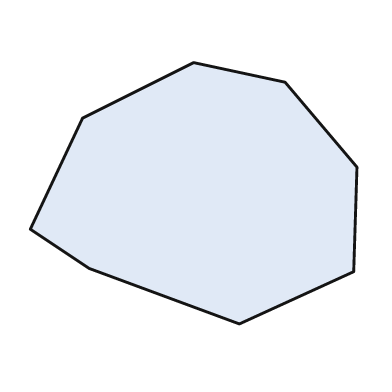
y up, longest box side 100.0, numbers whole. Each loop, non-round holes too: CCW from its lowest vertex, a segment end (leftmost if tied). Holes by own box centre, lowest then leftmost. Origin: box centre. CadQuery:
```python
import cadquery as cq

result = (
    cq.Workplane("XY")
    .moveTo(14.0, -40.0)
    .lineTo(49.0, -24.0)
    .lineTo(50.0, 8.0)
    .lineTo(28.0, 34.0)
    .lineTo(0.0, 40.0)
    .lineTo(-34.0, 23.0)
    .lineTo(-50.0, -11.0)
    .lineTo(-32.0, -23.0)
    .close()
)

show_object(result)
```